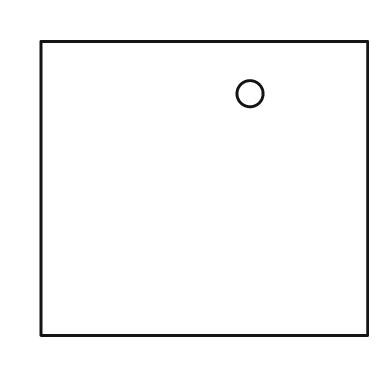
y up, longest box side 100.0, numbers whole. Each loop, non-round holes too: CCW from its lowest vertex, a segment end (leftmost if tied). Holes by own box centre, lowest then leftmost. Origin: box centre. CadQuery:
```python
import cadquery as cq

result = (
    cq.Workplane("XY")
    .moveTo(-50.0, -45.0)
    .lineTo(50.0, -45.0)
    .lineTo(50.0, 45.0)
    .lineTo(-50.0, 45.0)
    .close()
    .moveTo(14.0, 29.0)
    .circle(4.0)
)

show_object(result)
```